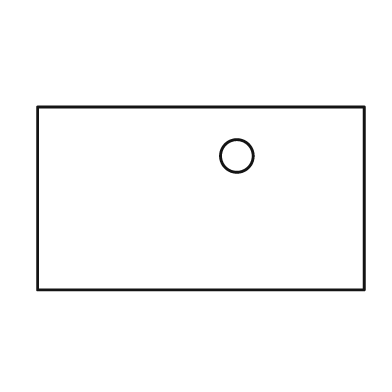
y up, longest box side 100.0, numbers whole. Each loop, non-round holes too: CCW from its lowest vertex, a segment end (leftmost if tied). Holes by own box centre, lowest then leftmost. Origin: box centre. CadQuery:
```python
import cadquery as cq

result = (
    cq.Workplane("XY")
    .moveTo(-50.0, -28.0)
    .lineTo(50.0, -28.0)
    .lineTo(50.0, 28.0)
    .lineTo(-50.0, 28.0)
    .close()
    .moveTo(11.0, 13.0)
    .circle(5.0)
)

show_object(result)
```